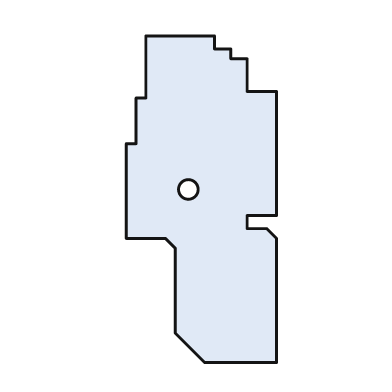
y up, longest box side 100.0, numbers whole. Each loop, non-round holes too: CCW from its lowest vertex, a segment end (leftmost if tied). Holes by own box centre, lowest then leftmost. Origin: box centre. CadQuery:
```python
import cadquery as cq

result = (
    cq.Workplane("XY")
    .moveTo(1.0, -50.0)
    .lineTo(23.0, -50.0)
    .lineTo(23.0, -12.0)
    .lineTo(20.0, -9.0)
    .lineTo(14.0, -9.0)
    .lineTo(14.0, -5.0)
    .lineTo(23.0, -5.0)
    .lineTo(23.0, 33.0)
    .lineTo(14.0, 33.0)
    .lineTo(14.0, 43.0)
    .lineTo(9.0, 43.0)
    .lineTo(9.0, 46.0)
    .lineTo(4.0, 46.0)
    .lineTo(4.0, 50.0)
    .lineTo(-17.0, 50.0)
    .lineTo(-17.0, 31.0)
    .lineTo(-20.0, 31.0)
    .lineTo(-20.0, 17.0)
    .lineTo(-23.0, 17.0)
    .lineTo(-23.0, -12.0)
    .lineTo(-11.0, -12.0)
    .lineTo(-8.0, -15.0)
    .lineTo(-8.0, -41.0)
    .close()
    .moveTo(-4.0, 3.0)
    .circle(3.0)
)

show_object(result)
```